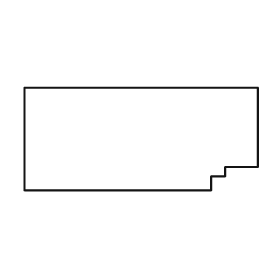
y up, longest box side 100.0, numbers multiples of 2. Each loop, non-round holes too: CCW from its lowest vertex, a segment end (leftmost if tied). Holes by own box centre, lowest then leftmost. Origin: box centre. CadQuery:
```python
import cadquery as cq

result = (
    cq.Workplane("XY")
    .moveTo(-50.0, -22.0)
    .lineTo(30.0, -22.0)
    .lineTo(30.0, -16.0)
    .lineTo(36.0, -16.0)
    .lineTo(36.0, -12.0)
    .lineTo(50.0, -12.0)
    .lineTo(50.0, 22.0)
    .lineTo(-50.0, 22.0)
    .close()
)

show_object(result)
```